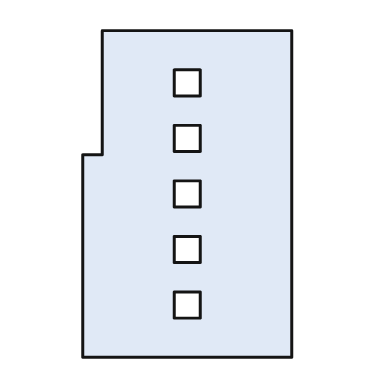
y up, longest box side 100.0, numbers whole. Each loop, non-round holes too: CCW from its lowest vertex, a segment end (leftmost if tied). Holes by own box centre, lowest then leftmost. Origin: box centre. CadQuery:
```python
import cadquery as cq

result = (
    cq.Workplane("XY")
    .moveTo(-32.0, -50.0)
    .lineTo(32.0, -50.0)
    .lineTo(32.0, 50.0)
    .lineTo(-26.0, 50.0)
    .lineTo(-26.0, 12.0)
    .lineTo(-32.0, 12.0)
    .close()
    .moveTo(-4.0, -38.0)
    .lineTo(4.0, -38.0)
    .lineTo(4.0, -30.0)
    .lineTo(-4.0, -30.0)
    .close()
    .moveTo(-4.0, -21.0)
    .lineTo(4.0, -21.0)
    .lineTo(4.0, -13.0)
    .lineTo(-4.0, -13.0)
    .close()
    .moveTo(-4.0, -4.0)
    .lineTo(4.0, -4.0)
    .lineTo(4.0, 4.0)
    .lineTo(-4.0, 4.0)
    .close()
    .moveTo(-4.0, 13.0)
    .lineTo(4.0, 13.0)
    .lineTo(4.0, 21.0)
    .lineTo(-4.0, 21.0)
    .close()
    .moveTo(-4.0, 30.0)
    .lineTo(4.0, 30.0)
    .lineTo(4.0, 38.0)
    .lineTo(-4.0, 38.0)
    .close()
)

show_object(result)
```